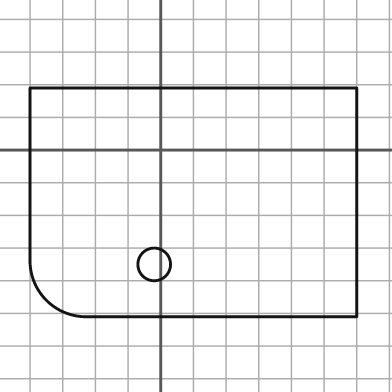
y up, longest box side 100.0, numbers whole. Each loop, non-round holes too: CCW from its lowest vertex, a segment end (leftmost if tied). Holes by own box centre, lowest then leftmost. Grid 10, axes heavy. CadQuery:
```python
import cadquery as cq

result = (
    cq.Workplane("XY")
    .moveTo(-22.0, -51.0)
    .lineTo(60.0, -51.0)
    .lineTo(60.0, 19.0)
    .lineTo(-40.0, 19.0)
    .lineTo(-40.0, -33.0)
    .threePointArc((-35.0, -46.0), (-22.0, -51.0))
    .close()
    .moveTo(-2.0, -35.0)
    .circle(5.0)
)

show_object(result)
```